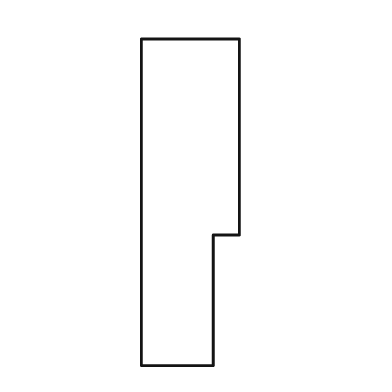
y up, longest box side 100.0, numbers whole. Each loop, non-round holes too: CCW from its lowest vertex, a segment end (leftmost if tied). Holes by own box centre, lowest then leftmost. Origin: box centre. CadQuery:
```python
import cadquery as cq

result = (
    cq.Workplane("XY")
    .moveTo(-15.0, -50.0)
    .lineTo(7.0, -50.0)
    .lineTo(7.0, -10.0)
    .lineTo(15.0, -10.0)
    .lineTo(15.0, 50.0)
    .lineTo(-15.0, 50.0)
    .close()
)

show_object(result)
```